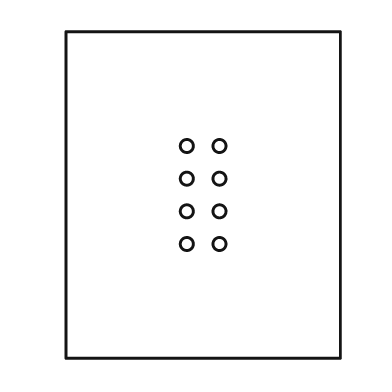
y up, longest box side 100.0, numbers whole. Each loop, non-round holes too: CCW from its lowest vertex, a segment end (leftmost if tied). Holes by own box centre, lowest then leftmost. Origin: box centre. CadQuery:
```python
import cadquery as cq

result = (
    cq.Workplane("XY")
    .moveTo(-42.0, -50.0)
    .lineTo(42.0, -50.0)
    .lineTo(42.0, 50.0)
    .lineTo(-42.0, 50.0)
    .close()
    .moveTo(-5.0, -15.0)
    .circle(2.0)
    .moveTo(5.0, -15.0)
    .circle(2.0)
    .moveTo(-5.0, -5.0)
    .circle(2.0)
    .moveTo(5.0, -5.0)
    .circle(2.0)
    .moveTo(-5.0, 5.0)
    .circle(2.0)
    .moveTo(5.0, 5.0)
    .circle(2.0)
    .moveTo(-5.0, 15.0)
    .circle(2.0)
    .moveTo(5.0, 15.0)
    .circle(2.0)
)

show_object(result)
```